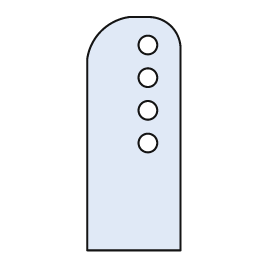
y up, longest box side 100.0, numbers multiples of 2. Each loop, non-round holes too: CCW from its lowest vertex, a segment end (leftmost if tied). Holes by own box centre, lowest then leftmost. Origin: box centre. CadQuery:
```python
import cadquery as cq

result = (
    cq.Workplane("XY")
    .moveTo(-20.0, -50.0)
    .lineTo(20.0, -50.0)
    .lineTo(20.0, 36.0)
    .threePointArc((16.0, 46.0), (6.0, 50.0))
    .lineTo(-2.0, 50.0)
    .threePointArc((-14.0, 44.0), (-20.0, 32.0))
    .close()
    .moveTo(6.0, -4.0)
    .circle(4.0)
    .moveTo(6.0, 10.0)
    .circle(4.0)
    .moveTo(6.0, 24.0)
    .circle(4.0)
    .moveTo(6.0, 38.0)
    .circle(4.0)
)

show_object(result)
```